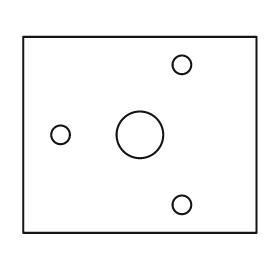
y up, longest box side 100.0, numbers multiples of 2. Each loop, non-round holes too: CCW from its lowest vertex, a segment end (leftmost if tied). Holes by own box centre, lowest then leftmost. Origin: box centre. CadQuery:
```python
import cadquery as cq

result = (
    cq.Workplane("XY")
    .moveTo(-50.0, -42.0)
    .lineTo(50.0, -42.0)
    .lineTo(50.0, 42.0)
    .lineTo(-50.0, 42.0)
    .close()
    .moveTo(18.0, -30.0)
    .circle(4.0)
    .moveTo(-34.0, 0.0)
    .circle(4.0)
    .moveTo(0.0, 0.0)
    .circle(10.0)
    .moveTo(18.0, 30.0)
    .circle(4.0)
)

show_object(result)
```